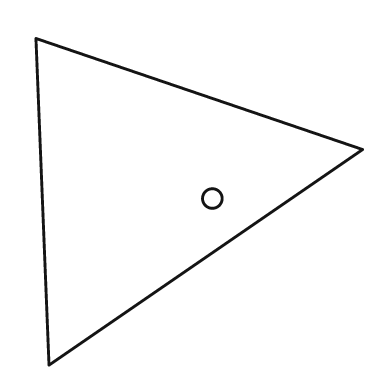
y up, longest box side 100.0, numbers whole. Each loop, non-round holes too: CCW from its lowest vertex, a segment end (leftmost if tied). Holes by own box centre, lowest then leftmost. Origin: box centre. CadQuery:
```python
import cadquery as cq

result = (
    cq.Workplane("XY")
    .moveTo(-46.0, -50.0)
    .lineTo(50.0, 16.0)
    .lineTo(-50.0, 50.0)
    .close()
    .moveTo(4.0, 1.0)
    .circle(3.0)
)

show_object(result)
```